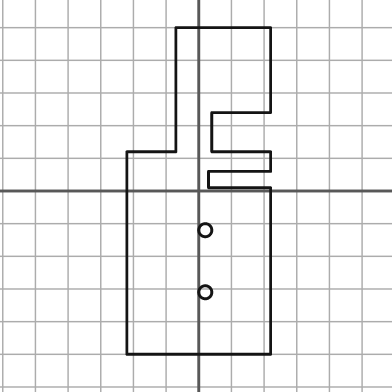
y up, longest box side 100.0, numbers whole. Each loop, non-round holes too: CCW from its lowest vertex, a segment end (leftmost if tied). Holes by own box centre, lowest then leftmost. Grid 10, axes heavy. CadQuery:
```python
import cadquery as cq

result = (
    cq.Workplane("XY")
    .moveTo(-22.0, -50.0)
    .lineTo(22.0, -50.0)
    .lineTo(22.0, 1.0)
    .lineTo(3.0, 1.0)
    .lineTo(3.0, 6.0)
    .lineTo(22.0, 6.0)
    .lineTo(22.0, 12.0)
    .lineTo(4.0, 12.0)
    .lineTo(4.0, 24.0)
    .lineTo(22.0, 24.0)
    .lineTo(22.0, 50.0)
    .lineTo(-7.0, 50.0)
    .lineTo(-7.0, 12.0)
    .lineTo(-22.0, 12.0)
    .close()
    .moveTo(2.0, -31.0)
    .circle(2.0)
    .moveTo(2.0, -12.0)
    .circle(2.0)
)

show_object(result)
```